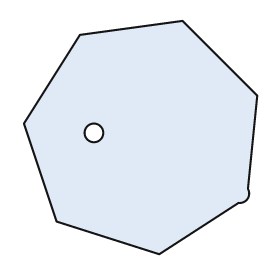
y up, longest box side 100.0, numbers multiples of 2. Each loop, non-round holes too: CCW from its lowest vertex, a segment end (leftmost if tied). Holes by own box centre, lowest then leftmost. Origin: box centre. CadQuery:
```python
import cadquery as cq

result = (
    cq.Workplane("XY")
    .moveTo(8.0, -50.0)
    .lineTo(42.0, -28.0)
    .threePointArc((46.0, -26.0), (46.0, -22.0))
    .lineTo(50.0, 18.0)
    .lineTo(18.0, 50.0)
    .lineTo(-26.0, 44.0)
    .lineTo(-50.0, 6.0)
    .lineTo(-36.0, -36.0)
    .close()
    .moveTo(-20.0, 2.0)
    .circle(4.0)
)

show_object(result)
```